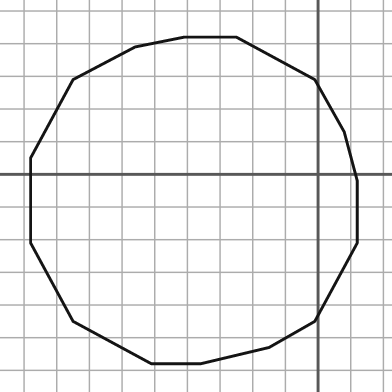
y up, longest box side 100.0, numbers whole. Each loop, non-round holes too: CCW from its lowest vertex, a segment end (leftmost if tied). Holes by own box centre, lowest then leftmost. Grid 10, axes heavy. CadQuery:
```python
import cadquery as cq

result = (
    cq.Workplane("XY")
    .moveTo(-51.0, -58.0)
    .lineTo(-36.0, -58.0)
    .lineTo(-15.0, -53.0)
    .lineTo(-1.0, -45.0)
    .lineTo(12.0, -21.0)
    .lineTo(12.0, -2.0)
    .lineTo(8.0, 13.0)
    .lineTo(-1.0, 29.0)
    .lineTo(-25.0, 42.0)
    .lineTo(-41.0, 42.0)
    .lineTo(-56.0, 39.0)
    .lineTo(-75.0, 29.0)
    .lineTo(-88.0, 5.0)
    .lineTo(-88.0, -21.0)
    .lineTo(-75.0, -45.0)
    .close()
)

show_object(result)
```